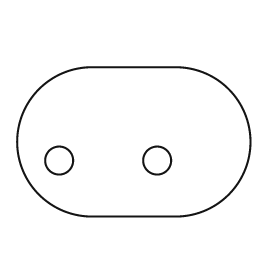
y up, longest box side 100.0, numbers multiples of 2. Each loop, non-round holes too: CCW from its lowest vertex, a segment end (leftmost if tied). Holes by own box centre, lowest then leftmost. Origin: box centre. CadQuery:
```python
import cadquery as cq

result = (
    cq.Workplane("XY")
    .moveTo(-18.0, -32.0)
    .lineTo(18.0, -32.0)
    .threePointArc((50.0, 0.0), (18.0, 32.0))
    .lineTo(-18.0, 32.0)
    .threePointArc((-50.0, 0.0), (-18.0, -32.0))
    .close()
    .moveTo(-32.0, -8.0)
    .circle(6.0)
    .moveTo(10.0, -8.0)
    .circle(6.0)
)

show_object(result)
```